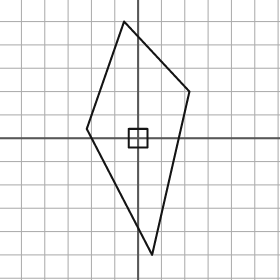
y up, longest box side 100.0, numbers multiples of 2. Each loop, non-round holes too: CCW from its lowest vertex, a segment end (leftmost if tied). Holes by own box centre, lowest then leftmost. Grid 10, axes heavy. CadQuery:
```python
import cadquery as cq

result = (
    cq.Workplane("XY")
    .moveTo(6.0, -50.0)
    .lineTo(22.0, 20.0)
    .lineTo(-6.0, 50.0)
    .lineTo(-22.0, 4.0)
    .close()
    .moveTo(-4.0, -4.0)
    .lineTo(4.0, -4.0)
    .lineTo(4.0, 4.0)
    .lineTo(-4.0, 4.0)
    .close()
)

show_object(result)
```